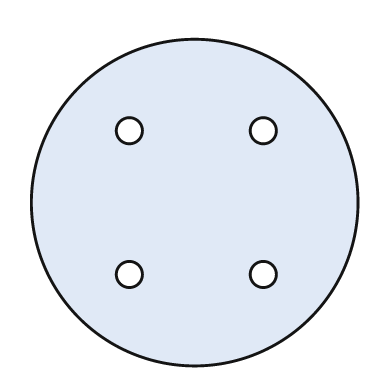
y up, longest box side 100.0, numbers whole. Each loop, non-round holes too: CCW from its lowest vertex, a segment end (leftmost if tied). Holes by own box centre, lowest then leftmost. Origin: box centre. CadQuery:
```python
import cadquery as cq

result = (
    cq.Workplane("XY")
    .moveTo(0.0, 0.0)
    .circle(50.0)
    .moveTo(-20.0, -22.0)
    .circle(4.0)
    .moveTo(21.0, -22.0)
    .circle(4.0)
    .moveTo(-20.0, 22.0)
    .circle(4.0)
    .moveTo(21.0, 22.0)
    .circle(4.0)
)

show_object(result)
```